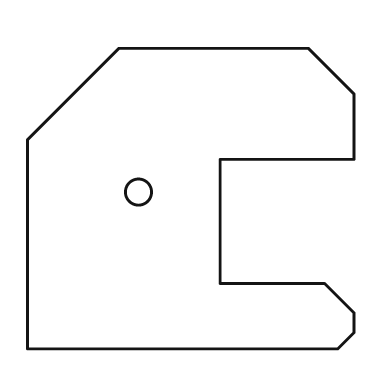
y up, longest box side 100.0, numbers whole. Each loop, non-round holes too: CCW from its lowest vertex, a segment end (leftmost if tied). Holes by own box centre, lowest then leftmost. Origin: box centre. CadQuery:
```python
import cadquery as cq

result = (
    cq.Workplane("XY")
    .moveTo(-50.0, -46.0)
    .lineTo(45.0, -46.0)
    .lineTo(50.0, -41.0)
    .lineTo(50.0, -35.0)
    .lineTo(41.0, -26.0)
    .lineTo(9.0, -26.0)
    .lineTo(9.0, 12.0)
    .lineTo(50.0, 12.0)
    .lineTo(50.0, 32.0)
    .lineTo(36.0, 46.0)
    .lineTo(-22.0, 46.0)
    .lineTo(-50.0, 18.0)
    .close()
    .moveTo(-16.0, 2.0)
    .circle(4.0)
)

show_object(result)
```